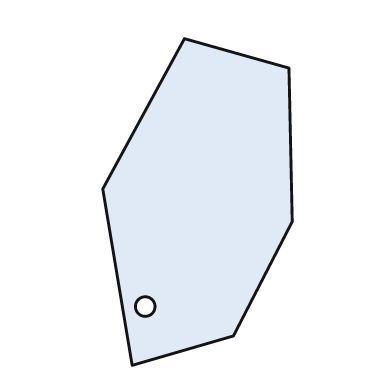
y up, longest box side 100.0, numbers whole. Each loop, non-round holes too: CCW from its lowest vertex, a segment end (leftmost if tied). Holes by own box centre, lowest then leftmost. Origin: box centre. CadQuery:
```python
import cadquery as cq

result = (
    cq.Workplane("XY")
    .moveTo(-20.0, -50.0)
    .lineTo(11.0, -41.0)
    .lineTo(29.0, -6.0)
    .lineTo(28.0, 41.0)
    .lineTo(-4.0, 50.0)
    .lineTo(-29.0, 4.0)
    .close()
    .moveTo(-16.0, -32.0)
    .circle(3.0)
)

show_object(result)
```